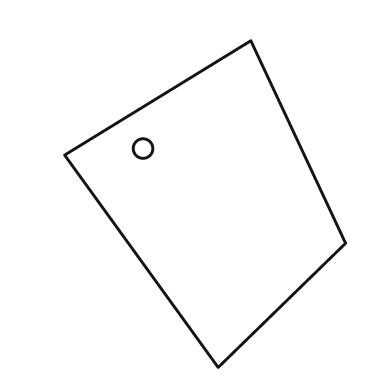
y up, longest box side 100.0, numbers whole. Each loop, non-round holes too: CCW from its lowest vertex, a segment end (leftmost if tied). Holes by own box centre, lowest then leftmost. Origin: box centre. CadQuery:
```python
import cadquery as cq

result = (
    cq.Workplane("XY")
    .moveTo(4.0, -50.0)
    .lineTo(43.0, -12.0)
    .lineTo(14.0, 50.0)
    .lineTo(-43.0, 15.0)
    .close()
    .moveTo(-19.0, 17.0)
    .circle(3.0)
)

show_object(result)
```